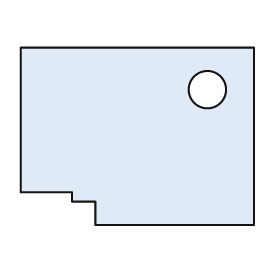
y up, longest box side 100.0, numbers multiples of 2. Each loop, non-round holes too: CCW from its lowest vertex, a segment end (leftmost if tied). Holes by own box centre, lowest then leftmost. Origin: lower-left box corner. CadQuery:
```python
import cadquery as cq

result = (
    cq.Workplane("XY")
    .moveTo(32.0, 0.0)
    .lineTo(100.0, 0.0)
    .lineTo(100.0, 76.0)
    .lineTo(0.0, 76.0)
    .lineTo(0.0, 14.0)
    .lineTo(22.0, 14.0)
    .lineTo(22.0, 10.0)
    .lineTo(32.0, 10.0)
    .close()
    .moveTo(80.0, 58.0)
    .circle(8.0)
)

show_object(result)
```